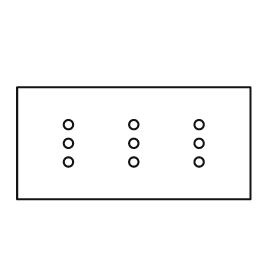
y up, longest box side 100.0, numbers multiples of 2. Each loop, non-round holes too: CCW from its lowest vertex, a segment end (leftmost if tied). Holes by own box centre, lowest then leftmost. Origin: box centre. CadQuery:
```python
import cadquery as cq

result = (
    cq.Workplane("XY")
    .moveTo(-50.0, -24.0)
    .lineTo(50.0, -24.0)
    .lineTo(50.0, 24.0)
    .lineTo(-50.0, 24.0)
    .close()
    .moveTo(-28.0, -8.0)
    .circle(2.0)
    .moveTo(0.0, -8.0)
    .circle(2.0)
    .moveTo(28.0, -8.0)
    .circle(2.0)
    .moveTo(-28.0, 0.0)
    .circle(2.0)
    .moveTo(0.0, 0.0)
    .circle(2.0)
    .moveTo(28.0, 0.0)
    .circle(2.0)
    .moveTo(-28.0, 8.0)
    .circle(2.0)
    .moveTo(0.0, 8.0)
    .circle(2.0)
    .moveTo(28.0, 8.0)
    .circle(2.0)
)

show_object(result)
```